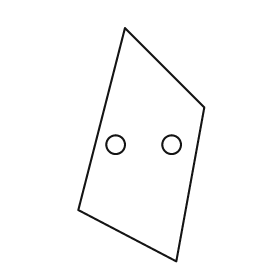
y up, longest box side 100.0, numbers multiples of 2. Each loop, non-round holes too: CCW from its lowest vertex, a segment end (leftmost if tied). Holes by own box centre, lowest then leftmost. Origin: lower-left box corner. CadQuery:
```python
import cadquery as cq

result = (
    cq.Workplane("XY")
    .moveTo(42.0, 0.0)
    .lineTo(54.0, 66.0)
    .lineTo(20.0, 100.0)
    .lineTo(0.0, 22.0)
    .close()
    .moveTo(16.0, 50.0)
    .circle(4.0)
    .moveTo(40.0, 50.0)
    .circle(4.0)
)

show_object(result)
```